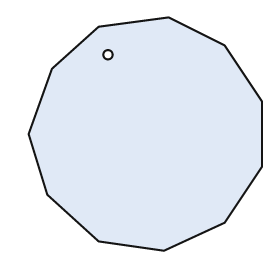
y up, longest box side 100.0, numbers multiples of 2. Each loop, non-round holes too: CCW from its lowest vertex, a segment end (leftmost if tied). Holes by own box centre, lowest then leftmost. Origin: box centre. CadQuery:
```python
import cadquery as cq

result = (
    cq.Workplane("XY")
    .moveTo(8.0, -50.0)
    .lineTo(34.0, -38.0)
    .lineTo(50.0, -14.0)
    .lineTo(50.0, 14.0)
    .lineTo(34.0, 38.0)
    .lineTo(10.0, 50.0)
    .lineTo(-20.0, 46.0)
    .lineTo(-40.0, 28.0)
    .lineTo(-50.0, 0.0)
    .lineTo(-42.0, -26.0)
    .lineTo(-20.0, -46.0)
    .close()
    .moveTo(-16.0, 34.0)
    .circle(2.0)
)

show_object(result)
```